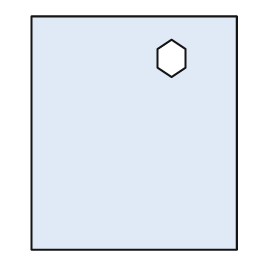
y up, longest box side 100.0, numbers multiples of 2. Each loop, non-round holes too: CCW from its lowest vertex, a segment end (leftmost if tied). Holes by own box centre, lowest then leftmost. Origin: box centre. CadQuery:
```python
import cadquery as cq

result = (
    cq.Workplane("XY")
    .moveTo(-44.0, -50.0)
    .lineTo(44.0, -50.0)
    .lineTo(44.0, 50.0)
    .lineTo(-44.0, 50.0)
    .close()
    .moveTo(16.0, 24.0)
    .lineTo(22.0, 28.0)
    .lineTo(22.0, 36.0)
    .lineTo(16.0, 40.0)
    .lineTo(10.0, 36.0)
    .lineTo(10.0, 28.0)
    .close()
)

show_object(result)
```